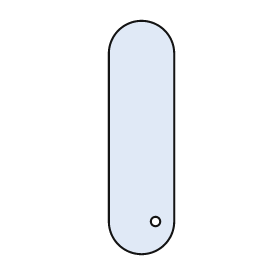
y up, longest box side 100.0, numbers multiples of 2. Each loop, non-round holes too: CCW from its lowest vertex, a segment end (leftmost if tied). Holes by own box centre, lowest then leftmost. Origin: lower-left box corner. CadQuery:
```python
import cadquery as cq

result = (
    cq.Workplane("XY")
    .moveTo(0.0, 14.0)
    .threePointArc((14.0, 0.0), (28.0, 14.0))
    .lineTo(28.0, 86.0)
    .threePointArc((14.0, 100.0), (0.0, 86.0))
    .close()
    .moveTo(20.0, 14.0)
    .circle(2.0)
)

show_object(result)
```